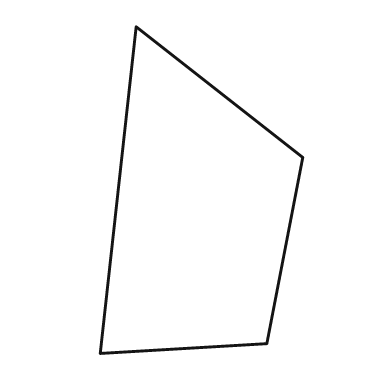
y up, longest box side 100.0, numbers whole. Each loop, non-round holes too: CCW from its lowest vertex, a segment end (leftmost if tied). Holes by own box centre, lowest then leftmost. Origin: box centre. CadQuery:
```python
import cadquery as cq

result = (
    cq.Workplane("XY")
    .moveTo(-31.0, -50.0)
    .lineTo(20.0, -47.0)
    .lineTo(31.0, 10.0)
    .lineTo(-20.0, 50.0)
    .close()
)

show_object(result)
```